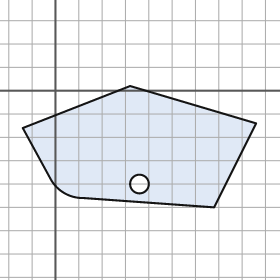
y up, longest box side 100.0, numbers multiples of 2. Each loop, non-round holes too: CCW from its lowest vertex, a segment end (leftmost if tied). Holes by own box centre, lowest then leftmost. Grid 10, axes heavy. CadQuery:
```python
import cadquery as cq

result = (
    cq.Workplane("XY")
    .moveTo(68.0, -50.0)
    .lineTo(86.0, -14.0)
    .lineTo(32.0, 2.0)
    .lineTo(-14.0, -16.0)
    .lineTo(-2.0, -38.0)
    .threePointArc((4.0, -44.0), (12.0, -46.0))
    .close()
    .moveTo(36.0, -40.0)
    .circle(4.0)
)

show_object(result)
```